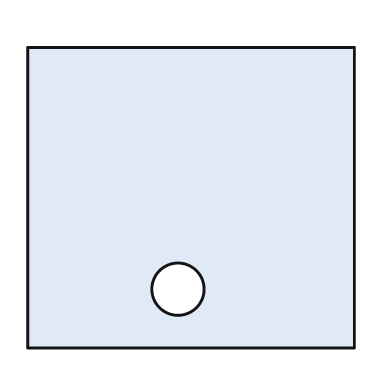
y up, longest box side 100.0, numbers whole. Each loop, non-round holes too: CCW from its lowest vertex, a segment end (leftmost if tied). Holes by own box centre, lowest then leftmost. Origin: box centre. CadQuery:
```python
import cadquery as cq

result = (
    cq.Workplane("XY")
    .moveTo(-50.0, -46.0)
    .lineTo(50.0, -46.0)
    .lineTo(50.0, 46.0)
    .lineTo(-50.0, 46.0)
    .close()
    .moveTo(-4.0, -28.0)
    .circle(8.0)
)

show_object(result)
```